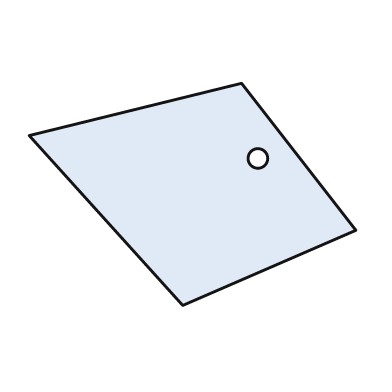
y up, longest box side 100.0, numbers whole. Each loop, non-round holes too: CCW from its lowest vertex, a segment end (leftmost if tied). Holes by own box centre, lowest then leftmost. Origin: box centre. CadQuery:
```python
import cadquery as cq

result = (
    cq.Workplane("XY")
    .moveTo(-3.0, -34.0)
    .lineTo(50.0, -11.0)
    .lineTo(15.0, 34.0)
    .lineTo(-50.0, 18.0)
    .close()
    .moveTo(20.0, 11.0)
    .circle(3.0)
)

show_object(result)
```